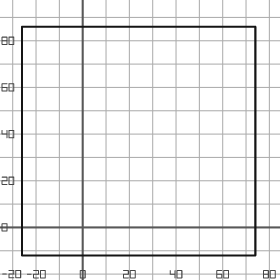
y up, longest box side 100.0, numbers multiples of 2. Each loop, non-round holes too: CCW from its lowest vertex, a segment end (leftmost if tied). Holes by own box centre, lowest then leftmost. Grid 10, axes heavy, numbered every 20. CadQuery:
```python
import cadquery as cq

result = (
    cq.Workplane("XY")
    .moveTo(-26.0, -12.0)
    .lineTo(74.0, -12.0)
    .lineTo(74.0, 86.0)
    .lineTo(-26.0, 86.0)
    .close()
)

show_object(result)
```